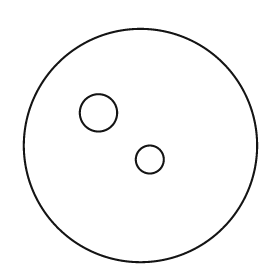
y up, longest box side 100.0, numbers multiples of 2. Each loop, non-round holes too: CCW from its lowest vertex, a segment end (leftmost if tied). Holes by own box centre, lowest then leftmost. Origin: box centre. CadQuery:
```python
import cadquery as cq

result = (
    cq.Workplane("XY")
    .moveTo(0.0, 0.0)
    .circle(50.0)
    .moveTo(4.0, -6.0)
    .circle(6.0)
    .moveTo(-18.0, 14.0)
    .circle(8.0)
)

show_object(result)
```